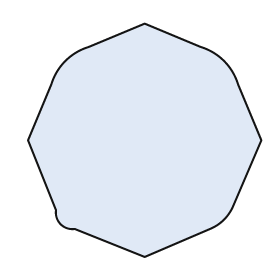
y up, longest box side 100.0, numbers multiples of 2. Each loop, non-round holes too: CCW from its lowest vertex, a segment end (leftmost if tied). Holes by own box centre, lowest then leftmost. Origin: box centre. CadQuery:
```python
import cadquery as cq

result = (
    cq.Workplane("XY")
    .moveTo(0.0, -50.0)
    .lineTo(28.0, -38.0)
    .threePointArc((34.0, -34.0), (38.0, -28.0))
    .lineTo(50.0, 0.0)
    .lineTo(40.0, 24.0)
    .threePointArc((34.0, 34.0), (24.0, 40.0))
    .lineTo(0.0, 50.0)
    .lineTo(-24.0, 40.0)
    .threePointArc((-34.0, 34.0), (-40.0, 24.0))
    .lineTo(-50.0, 0.0)
    .lineTo(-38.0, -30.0)
    .threePointArc((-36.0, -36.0), (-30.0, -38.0))
    .close()
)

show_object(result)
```